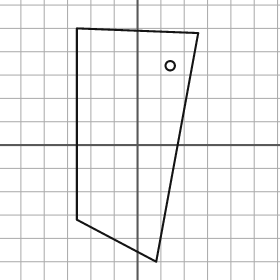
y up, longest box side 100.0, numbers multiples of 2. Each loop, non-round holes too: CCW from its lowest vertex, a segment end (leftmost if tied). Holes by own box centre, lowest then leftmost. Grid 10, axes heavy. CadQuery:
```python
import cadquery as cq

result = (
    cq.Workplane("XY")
    .moveTo(8.0, -50.0)
    .lineTo(26.0, 48.0)
    .lineTo(-26.0, 50.0)
    .lineTo(-26.0, -32.0)
    .close()
    .moveTo(14.0, 34.0)
    .circle(2.0)
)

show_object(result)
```